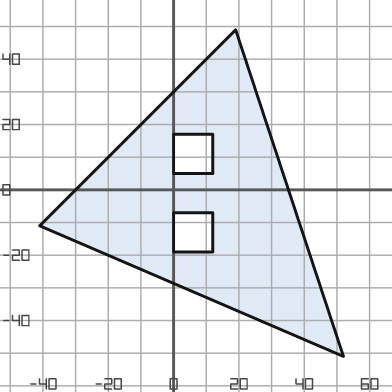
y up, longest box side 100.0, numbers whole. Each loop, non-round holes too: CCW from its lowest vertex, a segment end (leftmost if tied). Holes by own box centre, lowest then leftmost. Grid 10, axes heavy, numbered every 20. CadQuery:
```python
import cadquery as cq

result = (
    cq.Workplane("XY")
    .moveTo(52.0, -51.0)
    .lineTo(19.0, 49.0)
    .lineTo(-41.0, -11.0)
    .close()
    .moveTo(0.0, -19.0)
    .lineTo(12.0, -19.0)
    .lineTo(12.0, -7.0)
    .lineTo(0.0, -7.0)
    .close()
    .moveTo(0.0, 5.0)
    .lineTo(12.0, 5.0)
    .lineTo(12.0, 17.0)
    .lineTo(0.0, 17.0)
    .close()
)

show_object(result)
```